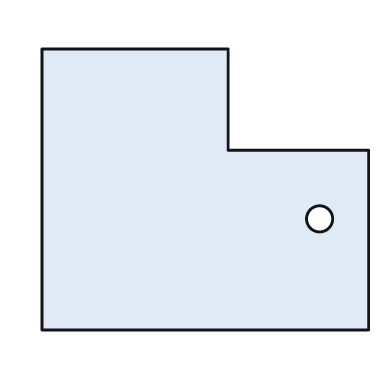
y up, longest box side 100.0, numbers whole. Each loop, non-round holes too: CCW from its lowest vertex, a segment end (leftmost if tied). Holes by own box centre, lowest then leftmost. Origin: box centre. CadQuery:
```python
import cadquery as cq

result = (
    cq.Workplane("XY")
    .moveTo(-50.0, -43.0)
    .lineTo(50.0, -43.0)
    .lineTo(50.0, 12.0)
    .lineTo(7.0, 12.0)
    .lineTo(7.0, 43.0)
    .lineTo(-50.0, 43.0)
    .close()
    .moveTo(35.0, -9.0)
    .circle(4.0)
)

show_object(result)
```